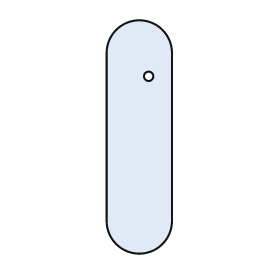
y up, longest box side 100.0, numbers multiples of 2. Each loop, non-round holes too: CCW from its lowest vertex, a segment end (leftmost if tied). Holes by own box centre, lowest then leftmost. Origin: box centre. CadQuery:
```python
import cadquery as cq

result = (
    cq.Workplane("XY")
    .moveTo(-14.0, -36.0)
    .threePointArc((0.0, -50.0), (14.0, -36.0))
    .lineTo(14.0, 36.0)
    .threePointArc((0.0, 50.0), (-14.0, 36.0))
    .close()
    .moveTo(4.0, 26.0)
    .circle(2.0)
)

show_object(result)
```